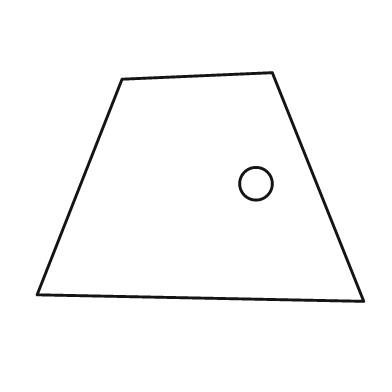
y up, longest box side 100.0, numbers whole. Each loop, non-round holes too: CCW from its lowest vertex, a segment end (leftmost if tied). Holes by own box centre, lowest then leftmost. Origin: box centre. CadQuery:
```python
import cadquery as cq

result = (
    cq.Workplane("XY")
    .moveTo(50.0, -35.0)
    .lineTo(22.0, 35.0)
    .lineTo(-24.0, 33.0)
    .lineTo(-50.0, -33.0)
    .close()
    .moveTo(17.0, 1.0)
    .circle(5.0)
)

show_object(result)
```